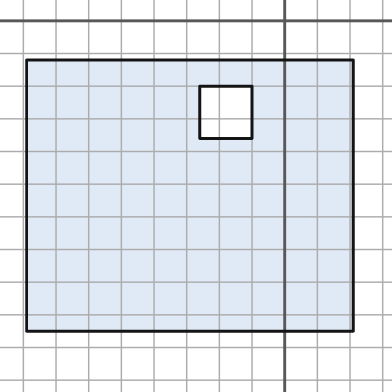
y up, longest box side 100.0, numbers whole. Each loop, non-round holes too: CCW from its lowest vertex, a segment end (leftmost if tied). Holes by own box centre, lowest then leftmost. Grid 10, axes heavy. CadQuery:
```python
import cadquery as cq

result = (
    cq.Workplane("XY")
    .moveTo(-79.0, -95.0)
    .lineTo(21.0, -95.0)
    .lineTo(21.0, -12.0)
    .lineTo(-79.0, -12.0)
    .close()
    .moveTo(-26.0, -36.0)
    .lineTo(-10.0, -36.0)
    .lineTo(-10.0, -20.0)
    .lineTo(-26.0, -20.0)
    .close()
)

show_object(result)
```